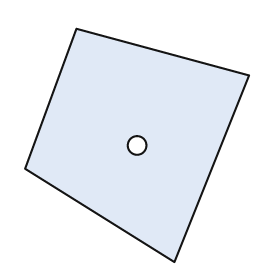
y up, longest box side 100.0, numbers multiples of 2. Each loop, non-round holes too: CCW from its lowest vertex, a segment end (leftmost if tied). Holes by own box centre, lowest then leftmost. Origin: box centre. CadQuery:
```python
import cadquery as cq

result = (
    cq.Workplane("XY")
    .moveTo(16.0, -50.0)
    .lineTo(48.0, 30.0)
    .lineTo(-26.0, 50.0)
    .lineTo(-48.0, -10.0)
    .close()
    .moveTo(0.0, 0.0)
    .circle(4.0)
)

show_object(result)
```